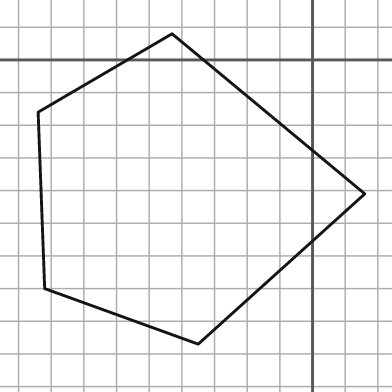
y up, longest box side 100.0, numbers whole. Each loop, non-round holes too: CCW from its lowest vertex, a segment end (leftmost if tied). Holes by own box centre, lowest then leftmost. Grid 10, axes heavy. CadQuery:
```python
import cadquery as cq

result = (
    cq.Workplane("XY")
    .moveTo(-35.0, -87.0)
    .lineTo(16.0, -41.0)
    .lineTo(-43.0, 8.0)
    .lineTo(-84.0, -16.0)
    .lineTo(-82.0, -70.0)
    .close()
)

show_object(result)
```